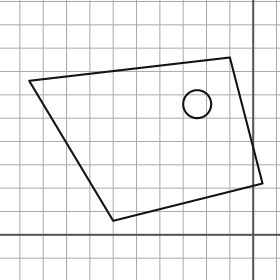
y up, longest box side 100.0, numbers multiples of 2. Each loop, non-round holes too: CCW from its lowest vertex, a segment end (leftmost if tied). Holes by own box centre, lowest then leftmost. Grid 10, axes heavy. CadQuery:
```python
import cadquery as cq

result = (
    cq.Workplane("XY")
    .moveTo(-60.0, 6.0)
    .lineTo(4.0, 22.0)
    .lineTo(-10.0, 76.0)
    .lineTo(-96.0, 66.0)
    .close()
    .moveTo(-24.0, 56.0)
    .circle(6.0)
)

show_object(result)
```